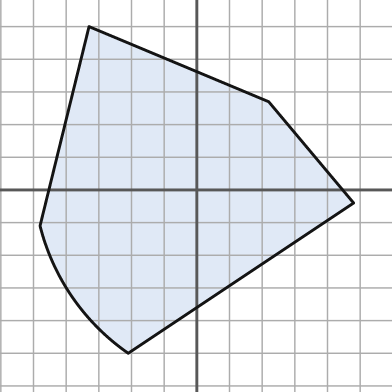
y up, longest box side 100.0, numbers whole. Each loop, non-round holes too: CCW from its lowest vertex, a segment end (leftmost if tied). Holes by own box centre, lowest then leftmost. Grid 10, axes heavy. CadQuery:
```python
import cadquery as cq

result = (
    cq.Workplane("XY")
    .moveTo(-21.0, -50.0)
    .lineTo(48.0, -4.0)
    .lineTo(22.0, 27.0)
    .lineTo(-33.0, 50.0)
    .lineTo(-48.0, -11.0)
    .threePointArc((-38.0, -33.0), (-21.0, -50.0))
    .close()
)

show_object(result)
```